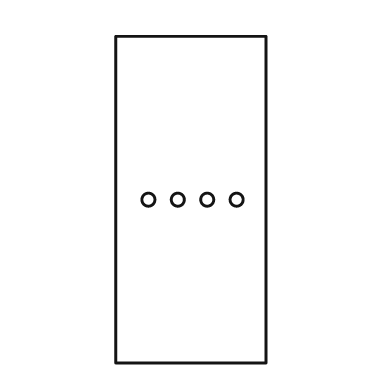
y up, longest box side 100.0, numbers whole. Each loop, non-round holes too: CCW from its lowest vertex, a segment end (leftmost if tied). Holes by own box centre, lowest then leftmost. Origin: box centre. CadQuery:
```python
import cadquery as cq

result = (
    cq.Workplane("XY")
    .moveTo(-23.0, -50.0)
    .lineTo(23.0, -50.0)
    .lineTo(23.0, 50.0)
    .lineTo(-23.0, 50.0)
    .close()
    .moveTo(-13.0, 0.0)
    .circle(2.0)
    .moveTo(-4.0, 0.0)
    .circle(2.0)
    .moveTo(5.0, 0.0)
    .circle(2.0)
    .moveTo(14.0, 0.0)
    .circle(2.0)
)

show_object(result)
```